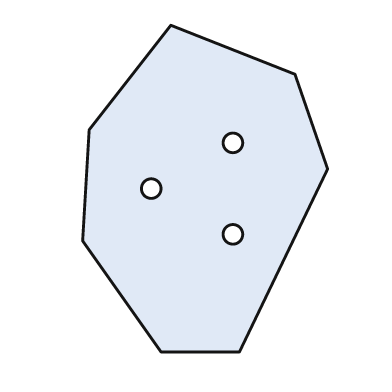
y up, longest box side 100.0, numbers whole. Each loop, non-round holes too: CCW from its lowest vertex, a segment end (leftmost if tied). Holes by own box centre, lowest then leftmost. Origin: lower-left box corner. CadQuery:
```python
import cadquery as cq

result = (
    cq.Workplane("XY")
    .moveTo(24.0, 0.0)
    .lineTo(48.0, 0.0)
    .lineTo(75.0, 56.0)
    .lineTo(65.0, 85.0)
    .lineTo(27.0, 100.0)
    .lineTo(2.0, 68.0)
    .lineTo(0.0, 34.0)
    .close()
    .moveTo(46.0, 36.0)
    .circle(3.0)
    .moveTo(21.0, 50.0)
    .circle(3.0)
    .moveTo(46.0, 64.0)
    .circle(3.0)
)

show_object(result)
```